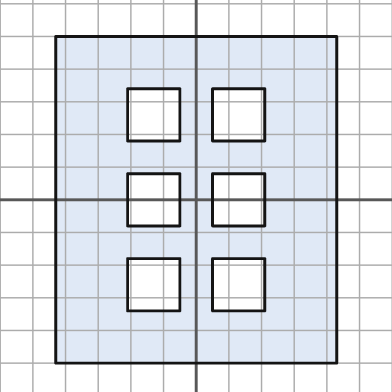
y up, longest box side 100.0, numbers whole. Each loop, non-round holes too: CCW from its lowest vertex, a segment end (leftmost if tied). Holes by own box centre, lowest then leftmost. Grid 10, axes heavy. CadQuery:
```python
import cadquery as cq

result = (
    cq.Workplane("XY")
    .moveTo(-43.0, -50.0)
    .lineTo(43.0, -50.0)
    .lineTo(43.0, 50.0)
    .lineTo(-43.0, 50.0)
    .close()
    .moveTo(-21.0, -34.0)
    .lineTo(-5.0, -34.0)
    .lineTo(-5.0, -18.0)
    .lineTo(-21.0, -18.0)
    .close()
    .moveTo(5.0, -34.0)
    .lineTo(21.0, -34.0)
    .lineTo(21.0, -18.0)
    .lineTo(5.0, -18.0)
    .close()
    .moveTo(-21.0, -8.0)
    .lineTo(-5.0, -8.0)
    .lineTo(-5.0, 8.0)
    .lineTo(-21.0, 8.0)
    .close()
    .moveTo(5.0, -8.0)
    .lineTo(21.0, -8.0)
    .lineTo(21.0, 8.0)
    .lineTo(5.0, 8.0)
    .close()
    .moveTo(-21.0, 18.0)
    .lineTo(-5.0, 18.0)
    .lineTo(-5.0, 34.0)
    .lineTo(-21.0, 34.0)
    .close()
    .moveTo(5.0, 18.0)
    .lineTo(21.0, 18.0)
    .lineTo(21.0, 34.0)
    .lineTo(5.0, 34.0)
    .close()
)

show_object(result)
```